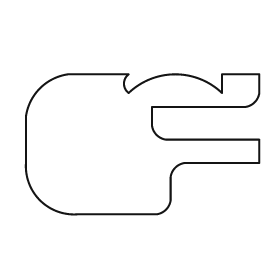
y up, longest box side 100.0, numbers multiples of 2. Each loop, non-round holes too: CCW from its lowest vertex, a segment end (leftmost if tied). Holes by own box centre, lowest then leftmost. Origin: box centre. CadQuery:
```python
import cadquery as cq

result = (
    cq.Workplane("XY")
    .moveTo(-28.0, -30.0)
    .lineTo(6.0, -30.0)
    .threePointArc((10.0, -28.0), (12.0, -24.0))
    .lineTo(12.0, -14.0)
    .threePointArc((14.0, -10.0), (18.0, -8.0))
    .lineTo(50.0, -8.0)
    .lineTo(50.0, 2.0)
    .lineTo(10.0, 2.0)
    .threePointArc((6.0, 4.0), (4.0, 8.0))
    .lineTo(4.0, 16.0)
    .lineTo(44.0, 16.0)
    .threePointArc((48.0, 18.0), (50.0, 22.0))
    .lineTo(50.0, 30.0)
    .lineTo(34.0, 30.0)
    .lineTo(34.0, 22.0)
    .threePointArc((14.0, 30.0), (-6.0, 22.0))
    .threePointArc((-8.0, 26.0), (-6.0, 30.0))
    .lineTo(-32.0, 30.0)
    .threePointArc((-44.0, 24.0), (-50.0, 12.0))
    .lineTo(-50.0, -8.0)
    .threePointArc((-44.0, -24.0), (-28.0, -30.0))
    .close()
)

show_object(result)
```